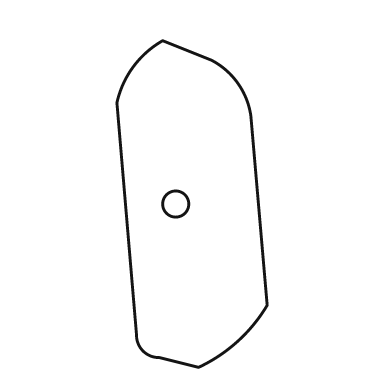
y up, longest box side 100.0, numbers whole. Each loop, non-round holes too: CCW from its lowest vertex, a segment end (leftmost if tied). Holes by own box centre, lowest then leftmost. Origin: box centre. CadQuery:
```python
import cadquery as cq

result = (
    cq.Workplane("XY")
    .moveTo(2.0, -50.0)
    .threePointArc((14.0, -42.0), (23.0, -31.0))
    .lineTo(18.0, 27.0)
    .threePointArc((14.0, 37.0), (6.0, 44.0))
    .lineTo(-9.0, 50.0)
    .threePointArc((-18.0, 42.0), (-23.0, 31.0))
    .lineTo(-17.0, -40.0)
    .threePointArc((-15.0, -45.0), (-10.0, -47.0))
    .close()
    .moveTo(-5.0, 0.0)
    .circle(4.0)
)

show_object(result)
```